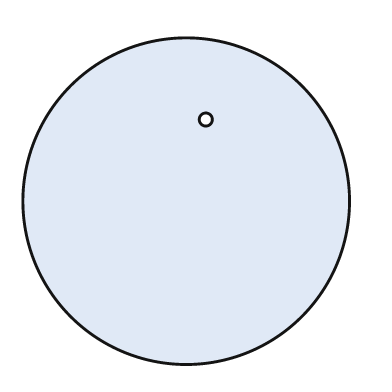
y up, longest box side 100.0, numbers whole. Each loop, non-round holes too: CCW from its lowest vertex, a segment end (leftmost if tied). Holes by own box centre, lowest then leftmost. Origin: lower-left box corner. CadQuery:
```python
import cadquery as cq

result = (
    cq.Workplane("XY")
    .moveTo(50.0, 50.0)
    .circle(50.0)
    .moveTo(56.0, 75.0)
    .circle(2.0)
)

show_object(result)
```